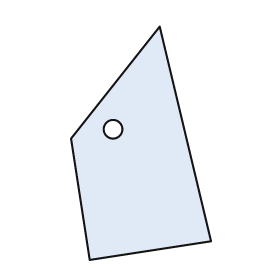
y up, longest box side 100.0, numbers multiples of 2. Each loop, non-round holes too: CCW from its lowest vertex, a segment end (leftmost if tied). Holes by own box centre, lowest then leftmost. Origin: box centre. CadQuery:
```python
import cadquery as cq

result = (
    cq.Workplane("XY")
    .moveTo(-22.0, -50.0)
    .lineTo(30.0, -42.0)
    .lineTo(8.0, 50.0)
    .lineTo(-30.0, 2.0)
    .close()
    .moveTo(-12.0, 6.0)
    .circle(4.0)
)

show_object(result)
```